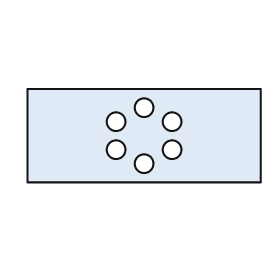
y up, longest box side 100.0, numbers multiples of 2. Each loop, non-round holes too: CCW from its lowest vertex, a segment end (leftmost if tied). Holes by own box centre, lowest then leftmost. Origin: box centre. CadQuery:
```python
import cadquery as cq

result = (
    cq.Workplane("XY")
    .moveTo(-50.0, -20.0)
    .lineTo(50.0, -20.0)
    .lineTo(50.0, 20.0)
    .lineTo(-50.0, 20.0)
    .close()
    .moveTo(0.0, -12.0)
    .circle(4.0)
    .moveTo(-12.0, -6.0)
    .circle(4.0)
    .moveTo(12.0, -6.0)
    .circle(4.0)
    .moveTo(-12.0, 6.0)
    .circle(4.0)
    .moveTo(12.0, 6.0)
    .circle(4.0)
    .moveTo(0.0, 12.0)
    .circle(4.0)
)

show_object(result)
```